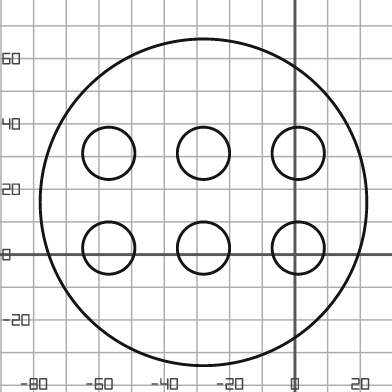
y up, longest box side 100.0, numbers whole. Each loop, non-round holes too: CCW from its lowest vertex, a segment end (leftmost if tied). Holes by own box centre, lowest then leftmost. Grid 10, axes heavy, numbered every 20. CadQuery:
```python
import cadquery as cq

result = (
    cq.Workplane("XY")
    .moveTo(-28.0, 16.0)
    .circle(50.0)
    .moveTo(-57.0, 2.0)
    .circle(8.0)
    .moveTo(-28.0, 2.0)
    .circle(8.0)
    .moveTo(1.0, 2.0)
    .circle(8.0)
    .moveTo(-57.0, 31.0)
    .circle(8.0)
    .moveTo(-28.0, 31.0)
    .circle(8.0)
    .moveTo(1.0, 31.0)
    .circle(8.0)
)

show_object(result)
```